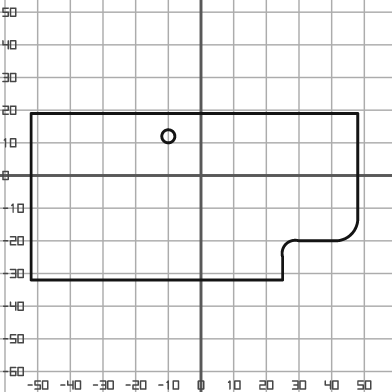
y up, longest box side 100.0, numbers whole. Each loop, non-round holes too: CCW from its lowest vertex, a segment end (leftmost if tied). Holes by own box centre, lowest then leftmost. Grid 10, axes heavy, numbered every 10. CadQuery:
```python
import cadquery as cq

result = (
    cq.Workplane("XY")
    .moveTo(-52.0, -32.0)
    .lineTo(25.0, -32.0)
    .lineTo(25.0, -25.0)
    .threePointArc((26.0, -21.0), (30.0, -20.0))
    .lineTo(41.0, -20.0)
    .threePointArc((46.0, -18.0), (48.0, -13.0))
    .lineTo(48.0, 19.0)
    .lineTo(-52.0, 19.0)
    .close()
    .moveTo(-10.0, 12.0)
    .circle(2.0)
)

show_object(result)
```